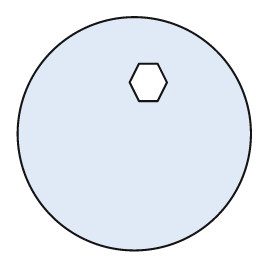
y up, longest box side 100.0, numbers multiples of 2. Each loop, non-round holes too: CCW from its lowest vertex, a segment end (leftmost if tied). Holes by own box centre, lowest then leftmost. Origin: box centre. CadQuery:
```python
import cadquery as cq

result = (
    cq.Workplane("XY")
    .moveTo(0.0, 0.0)
    .circle(50.0)
    .moveTo(2.0, 14.0)
    .lineTo(10.0, 14.0)
    .lineTo(14.0, 22.0)
    .lineTo(10.0, 30.0)
    .lineTo(2.0, 30.0)
    .lineTo(-2.0, 22.0)
    .close()
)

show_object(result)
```